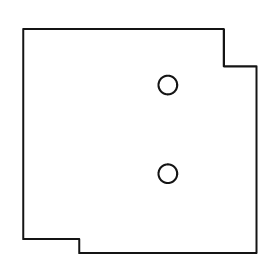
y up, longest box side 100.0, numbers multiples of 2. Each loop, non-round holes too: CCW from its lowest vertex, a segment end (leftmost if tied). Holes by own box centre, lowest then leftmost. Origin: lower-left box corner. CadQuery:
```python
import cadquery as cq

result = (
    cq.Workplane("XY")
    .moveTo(24.0, 0.0)
    .lineTo(100.0, 0.0)
    .lineTo(100.0, 80.0)
    .lineTo(86.0, 80.0)
    .lineTo(86.0, 96.0)
    .lineTo(0.0, 96.0)
    .lineTo(0.0, 6.0)
    .lineTo(24.0, 6.0)
    .close()
    .moveTo(62.0, 34.0)
    .circle(4.0)
    .moveTo(62.0, 72.0)
    .circle(4.0)
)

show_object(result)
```